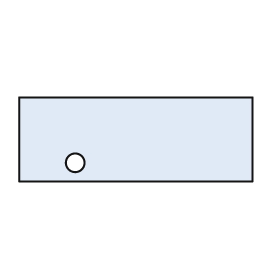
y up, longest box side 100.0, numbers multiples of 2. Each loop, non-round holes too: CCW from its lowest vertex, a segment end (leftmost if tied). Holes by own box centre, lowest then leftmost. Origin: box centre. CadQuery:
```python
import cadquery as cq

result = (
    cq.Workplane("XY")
    .moveTo(-50.0, -18.0)
    .lineTo(50.0, -18.0)
    .lineTo(50.0, 18.0)
    .lineTo(-50.0, 18.0)
    .close()
    .moveTo(-26.0, -10.0)
    .circle(4.0)
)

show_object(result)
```